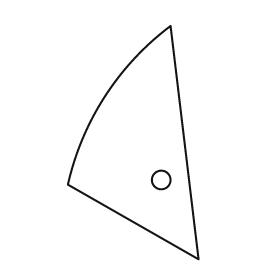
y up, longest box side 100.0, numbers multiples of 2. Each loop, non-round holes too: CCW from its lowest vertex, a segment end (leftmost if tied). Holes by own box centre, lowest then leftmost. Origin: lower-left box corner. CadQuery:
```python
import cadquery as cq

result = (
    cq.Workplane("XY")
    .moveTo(56.0, 0.0)
    .lineTo(44.0, 100.0)
    .threePointArc((16.0, 70.0), (0.0, 32.0))
    .close()
    .moveTo(40.0, 34.0)
    .circle(4.0)
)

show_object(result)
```